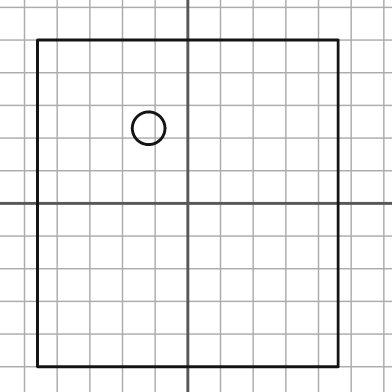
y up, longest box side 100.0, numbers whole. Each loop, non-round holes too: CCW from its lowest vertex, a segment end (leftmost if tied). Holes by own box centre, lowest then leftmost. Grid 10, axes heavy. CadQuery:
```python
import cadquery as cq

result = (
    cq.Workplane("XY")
    .moveTo(-46.0, -50.0)
    .lineTo(46.0, -50.0)
    .lineTo(46.0, 50.0)
    .lineTo(-46.0, 50.0)
    .close()
    .moveTo(-12.0, 23.0)
    .circle(5.0)
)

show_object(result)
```